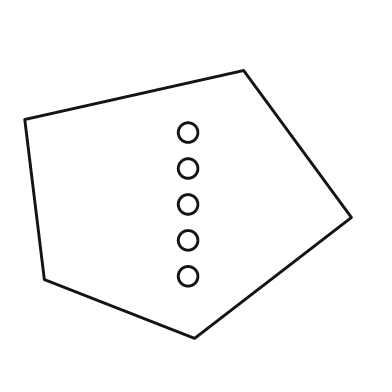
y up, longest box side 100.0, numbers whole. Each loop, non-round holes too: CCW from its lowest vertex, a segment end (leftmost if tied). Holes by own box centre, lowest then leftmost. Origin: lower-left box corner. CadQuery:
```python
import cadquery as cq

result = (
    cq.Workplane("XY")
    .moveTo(52.0, 0.0)
    .lineTo(100.0, 37.0)
    .lineTo(67.0, 82.0)
    .lineTo(0.0, 67.0)
    .lineTo(6.0, 18.0)
    .close()
    .moveTo(50.0, 19.0)
    .circle(3.0)
    .moveTo(50.0, 30.0)
    .circle(3.0)
    .moveTo(50.0, 41.0)
    .circle(3.0)
    .moveTo(50.0, 52.0)
    .circle(3.0)
    .moveTo(50.0, 63.0)
    .circle(3.0)
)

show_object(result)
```